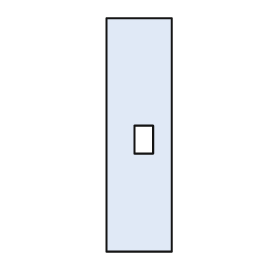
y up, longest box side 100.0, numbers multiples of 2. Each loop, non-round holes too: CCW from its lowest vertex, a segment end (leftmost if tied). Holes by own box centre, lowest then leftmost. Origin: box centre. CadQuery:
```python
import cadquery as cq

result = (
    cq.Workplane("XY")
    .moveTo(-14.0, -50.0)
    .lineTo(14.0, -50.0)
    .lineTo(14.0, 50.0)
    .lineTo(-14.0, 50.0)
    .close()
    .moveTo(-2.0, -8.0)
    .lineTo(6.0, -8.0)
    .lineTo(6.0, 4.0)
    .lineTo(-2.0, 4.0)
    .close()
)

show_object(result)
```